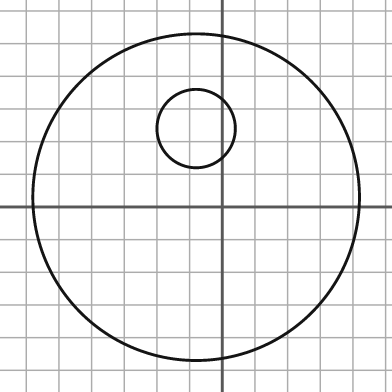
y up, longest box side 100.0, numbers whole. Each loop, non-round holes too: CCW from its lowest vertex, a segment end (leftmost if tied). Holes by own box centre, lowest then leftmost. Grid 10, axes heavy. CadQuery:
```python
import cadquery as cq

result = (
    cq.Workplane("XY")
    .moveTo(-8.0, 3.0)
    .circle(50.0)
    .moveTo(-8.0, 24.0)
    .circle(12.0)
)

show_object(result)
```